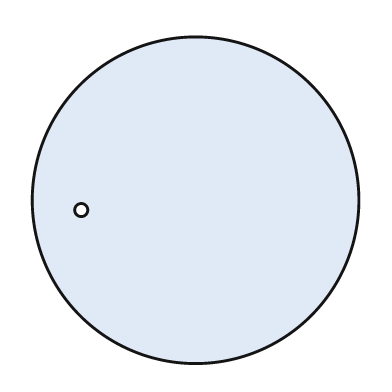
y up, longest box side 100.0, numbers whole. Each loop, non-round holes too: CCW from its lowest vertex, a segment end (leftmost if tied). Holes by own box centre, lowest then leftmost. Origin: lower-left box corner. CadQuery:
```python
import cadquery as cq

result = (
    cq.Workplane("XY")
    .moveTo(50.0, 50.0)
    .circle(50.0)
    .moveTo(15.0, 47.0)
    .circle(2.0)
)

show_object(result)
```